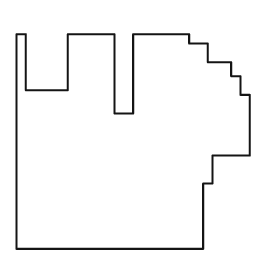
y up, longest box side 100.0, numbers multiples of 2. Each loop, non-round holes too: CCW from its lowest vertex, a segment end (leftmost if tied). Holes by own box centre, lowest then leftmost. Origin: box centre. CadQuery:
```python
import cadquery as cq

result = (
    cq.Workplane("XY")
    .moveTo(-50.0, -46.0)
    .lineTo(30.0, -46.0)
    .lineTo(30.0, -18.0)
    .lineTo(34.0, -18.0)
    .lineTo(34.0, -6.0)
    .lineTo(50.0, -6.0)
    .lineTo(50.0, 20.0)
    .lineTo(46.0, 20.0)
    .lineTo(46.0, 28.0)
    .lineTo(42.0, 28.0)
    .lineTo(42.0, 34.0)
    .lineTo(32.0, 34.0)
    .lineTo(32.0, 42.0)
    .lineTo(24.0, 42.0)
    .lineTo(24.0, 46.0)
    .lineTo(0.0, 46.0)
    .lineTo(0.0, 12.0)
    .lineTo(-8.0, 12.0)
    .lineTo(-8.0, 46.0)
    .lineTo(-28.0, 46.0)
    .lineTo(-28.0, 22.0)
    .lineTo(-46.0, 22.0)
    .lineTo(-46.0, 46.0)
    .lineTo(-50.0, 46.0)
    .close()
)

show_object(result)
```